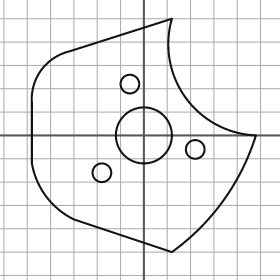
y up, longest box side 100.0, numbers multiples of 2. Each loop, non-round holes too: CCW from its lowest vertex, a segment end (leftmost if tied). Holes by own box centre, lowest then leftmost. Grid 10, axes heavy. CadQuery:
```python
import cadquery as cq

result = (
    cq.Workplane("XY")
    .moveTo(12.0, -50.0)
    .threePointArc((34.0, -28.0), (48.0, 0.0))
    .threePointArc((18.0, 16.0), (12.0, 50.0))
    .lineTo(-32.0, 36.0)
    .threePointArc((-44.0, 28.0), (-48.0, 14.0))
    .lineTo(-48.0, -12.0)
    .threePointArc((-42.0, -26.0), (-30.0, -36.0))
    .close()
    .moveTo(-18.0, -16.0)
    .circle(4.0)
    .moveTo(22.0, -6.0)
    .circle(4.0)
    .moveTo(0.0, 0.0)
    .circle(12.0)
    .moveTo(-6.0, 22.0)
    .circle(4.0)
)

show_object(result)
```